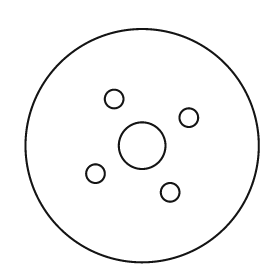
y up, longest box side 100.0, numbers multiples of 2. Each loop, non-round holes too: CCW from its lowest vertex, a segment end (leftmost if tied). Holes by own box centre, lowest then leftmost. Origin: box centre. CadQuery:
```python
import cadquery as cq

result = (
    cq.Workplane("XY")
    .moveTo(0.0, 0.0)
    .circle(50.0)
    .moveTo(12.0, -20.0)
    .circle(4.0)
    .moveTo(-20.0, -12.0)
    .circle(4.0)
    .moveTo(0.0, 0.0)
    .circle(10.0)
    .moveTo(20.0, 12.0)
    .circle(4.0)
    .moveTo(-12.0, 20.0)
    .circle(4.0)
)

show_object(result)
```